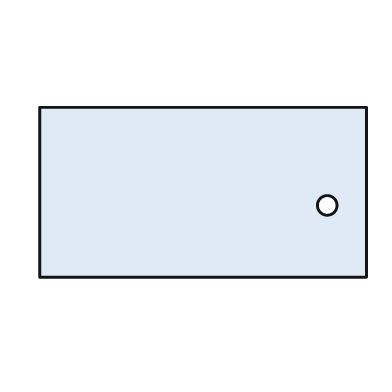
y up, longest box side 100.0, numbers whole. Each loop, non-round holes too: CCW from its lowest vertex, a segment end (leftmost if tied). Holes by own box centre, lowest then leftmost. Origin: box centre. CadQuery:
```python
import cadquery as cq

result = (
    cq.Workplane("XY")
    .moveTo(-50.0, -26.0)
    .lineTo(50.0, -26.0)
    .lineTo(50.0, 26.0)
    .lineTo(-50.0, 26.0)
    .close()
    .moveTo(38.0, -4.0)
    .circle(3.0)
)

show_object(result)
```